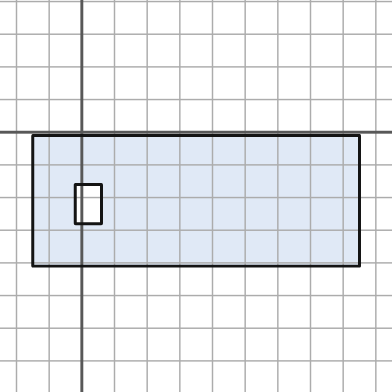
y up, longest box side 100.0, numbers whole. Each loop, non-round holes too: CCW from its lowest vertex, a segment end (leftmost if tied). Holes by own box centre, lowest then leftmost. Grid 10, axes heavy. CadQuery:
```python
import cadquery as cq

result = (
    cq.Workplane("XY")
    .moveTo(-15.0, -41.0)
    .lineTo(85.0, -41.0)
    .lineTo(85.0, -1.0)
    .lineTo(-15.0, -1.0)
    .close()
    .moveTo(-2.0, -28.0)
    .lineTo(6.0, -28.0)
    .lineTo(6.0, -16.0)
    .lineTo(-2.0, -16.0)
    .close()
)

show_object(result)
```